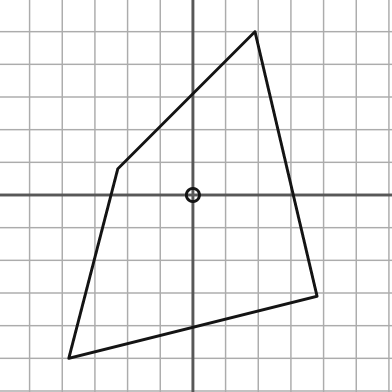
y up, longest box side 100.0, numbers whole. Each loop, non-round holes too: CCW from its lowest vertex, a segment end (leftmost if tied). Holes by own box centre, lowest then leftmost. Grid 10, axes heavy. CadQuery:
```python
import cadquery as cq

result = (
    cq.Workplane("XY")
    .moveTo(-38.0, -50.0)
    .lineTo(38.0, -31.0)
    .lineTo(19.0, 50.0)
    .lineTo(-23.0, 8.0)
    .close()
    .moveTo(0.0, 0.0)
    .circle(2.0)
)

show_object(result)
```